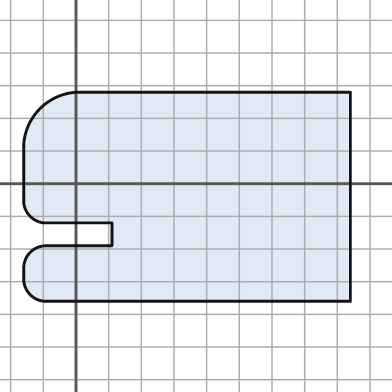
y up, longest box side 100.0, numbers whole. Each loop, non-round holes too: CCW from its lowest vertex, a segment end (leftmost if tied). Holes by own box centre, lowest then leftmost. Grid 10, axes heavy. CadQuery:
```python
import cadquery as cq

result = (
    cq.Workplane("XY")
    .moveTo(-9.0, -36.0)
    .lineTo(84.0, -36.0)
    .lineTo(84.0, 28.0)
    .lineTo(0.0, 28.0)
    .threePointArc((-11.0, 23.0), (-16.0, 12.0))
    .lineTo(-16.0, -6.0)
    .threePointArc((-14.0, -10.0), (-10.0, -12.0))
    .lineTo(11.0, -12.0)
    .lineTo(11.0, -19.0)
    .lineTo(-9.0, -19.0)
    .threePointArc((-14.0, -21.0), (-16.0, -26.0))
    .lineTo(-16.0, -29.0)
    .threePointArc((-14.0, -34.0), (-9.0, -36.0))
    .close()
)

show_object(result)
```